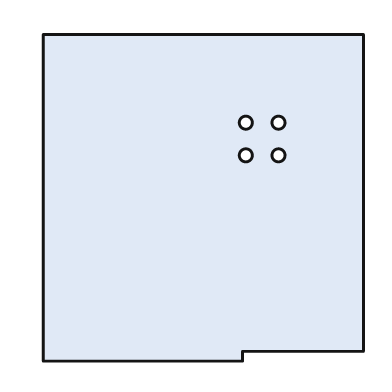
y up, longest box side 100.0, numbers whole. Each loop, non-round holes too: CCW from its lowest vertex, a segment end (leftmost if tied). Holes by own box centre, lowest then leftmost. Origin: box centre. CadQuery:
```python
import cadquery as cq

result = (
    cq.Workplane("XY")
    .moveTo(-49.0, -50.0)
    .lineTo(12.0, -50.0)
    .lineTo(12.0, -47.0)
    .lineTo(49.0, -47.0)
    .lineTo(49.0, 50.0)
    .lineTo(-49.0, 50.0)
    .close()
    .moveTo(13.0, 13.0)
    .circle(2.0)
    .moveTo(23.0, 13.0)
    .circle(2.0)
    .moveTo(13.0, 23.0)
    .circle(2.0)
    .moveTo(23.0, 23.0)
    .circle(2.0)
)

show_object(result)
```